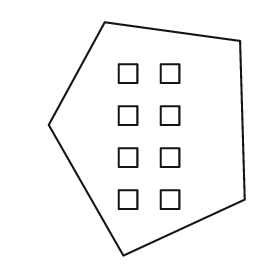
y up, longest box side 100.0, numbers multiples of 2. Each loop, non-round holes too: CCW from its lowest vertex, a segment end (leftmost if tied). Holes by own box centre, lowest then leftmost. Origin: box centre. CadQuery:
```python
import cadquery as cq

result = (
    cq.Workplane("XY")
    .moveTo(-10.0, -50.0)
    .lineTo(42.0, -26.0)
    .lineTo(40.0, 42.0)
    .lineTo(-18.0, 50.0)
    .lineTo(-42.0, 6.0)
    .close()
    .moveTo(-12.0, -30.0)
    .lineTo(-4.0, -30.0)
    .lineTo(-4.0, -22.0)
    .lineTo(-12.0, -22.0)
    .close()
    .moveTo(6.0, -30.0)
    .lineTo(14.0, -30.0)
    .lineTo(14.0, -22.0)
    .lineTo(6.0, -22.0)
    .close()
    .moveTo(-12.0, -12.0)
    .lineTo(-4.0, -12.0)
    .lineTo(-4.0, -4.0)
    .lineTo(-12.0, -4.0)
    .close()
    .moveTo(6.0, -12.0)
    .lineTo(14.0, -12.0)
    .lineTo(14.0, -4.0)
    .lineTo(6.0, -4.0)
    .close()
    .moveTo(-12.0, 6.0)
    .lineTo(-4.0, 6.0)
    .lineTo(-4.0, 14.0)
    .lineTo(-12.0, 14.0)
    .close()
    .moveTo(6.0, 6.0)
    .lineTo(14.0, 6.0)
    .lineTo(14.0, 14.0)
    .lineTo(6.0, 14.0)
    .close()
    .moveTo(-12.0, 24.0)
    .lineTo(-4.0, 24.0)
    .lineTo(-4.0, 32.0)
    .lineTo(-12.0, 32.0)
    .close()
    .moveTo(6.0, 24.0)
    .lineTo(14.0, 24.0)
    .lineTo(14.0, 32.0)
    .lineTo(6.0, 32.0)
    .close()
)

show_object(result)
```